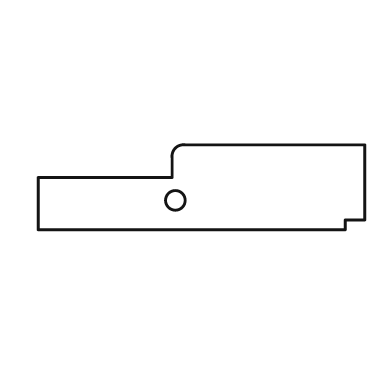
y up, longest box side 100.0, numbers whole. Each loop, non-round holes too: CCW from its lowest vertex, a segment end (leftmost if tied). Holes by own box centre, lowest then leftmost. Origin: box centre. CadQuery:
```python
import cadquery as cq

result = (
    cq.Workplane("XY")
    .moveTo(-50.0, -13.0)
    .lineTo(44.0, -13.0)
    .lineTo(44.0, -10.0)
    .lineTo(50.0, -10.0)
    .lineTo(50.0, 13.0)
    .lineTo(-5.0, 13.0)
    .threePointArc((-8.0, 12.0), (-9.0, 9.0))
    .lineTo(-9.0, 3.0)
    .lineTo(-50.0, 3.0)
    .close()
    .moveTo(-8.0, -4.0)
    .circle(3.0)
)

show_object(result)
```